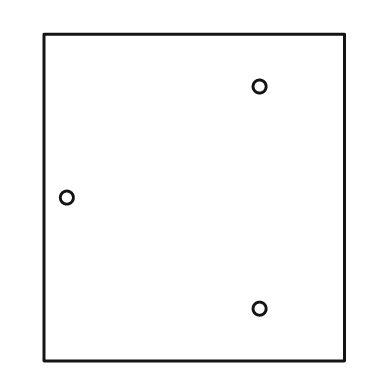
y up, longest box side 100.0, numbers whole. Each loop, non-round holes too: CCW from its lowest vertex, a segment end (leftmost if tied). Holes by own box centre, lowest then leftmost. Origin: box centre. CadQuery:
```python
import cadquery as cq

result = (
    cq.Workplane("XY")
    .moveTo(-46.0, -50.0)
    .lineTo(46.0, -50.0)
    .lineTo(46.0, 50.0)
    .lineTo(-46.0, 50.0)
    .close()
    .moveTo(20.0, -34.0)
    .circle(2.0)
    .moveTo(-39.0, 0.0)
    .circle(2.0)
    .moveTo(20.0, 34.0)
    .circle(2.0)
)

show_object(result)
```